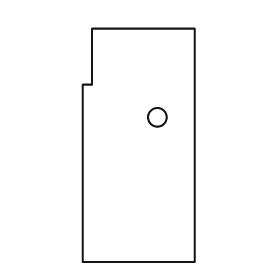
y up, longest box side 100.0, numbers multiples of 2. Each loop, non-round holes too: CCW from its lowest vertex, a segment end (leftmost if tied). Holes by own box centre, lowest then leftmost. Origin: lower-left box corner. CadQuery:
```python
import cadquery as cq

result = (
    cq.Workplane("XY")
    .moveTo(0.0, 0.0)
    .lineTo(48.0, 0.0)
    .lineTo(48.0, 100.0)
    .lineTo(4.0, 100.0)
    .lineTo(4.0, 76.0)
    .lineTo(0.0, 76.0)
    .close()
    .moveTo(32.0, 62.0)
    .circle(4.0)
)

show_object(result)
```